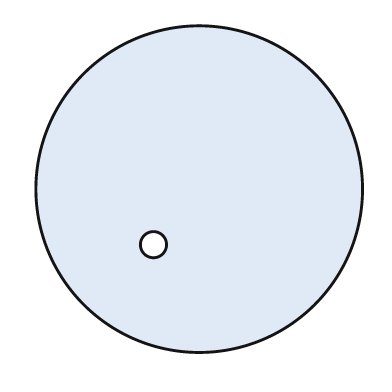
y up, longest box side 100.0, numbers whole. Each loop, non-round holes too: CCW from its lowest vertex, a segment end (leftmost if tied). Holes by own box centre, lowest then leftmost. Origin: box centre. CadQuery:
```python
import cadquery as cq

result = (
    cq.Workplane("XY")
    .moveTo(0.0, 0.0)
    .circle(50.0)
    .moveTo(-14.0, -17.0)
    .circle(4.0)
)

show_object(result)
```